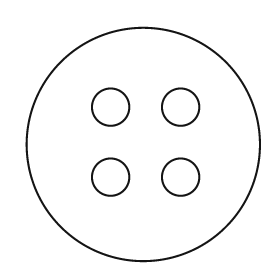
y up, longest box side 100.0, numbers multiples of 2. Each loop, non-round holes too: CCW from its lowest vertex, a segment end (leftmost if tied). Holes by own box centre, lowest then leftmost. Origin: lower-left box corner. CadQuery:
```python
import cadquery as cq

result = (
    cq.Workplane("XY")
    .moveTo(50.0, 50.0)
    .circle(50.0)
    .moveTo(36.0, 36.0)
    .circle(8.0)
    .moveTo(66.0, 36.0)
    .circle(8.0)
    .moveTo(36.0, 66.0)
    .circle(8.0)
    .moveTo(66.0, 66.0)
    .circle(8.0)
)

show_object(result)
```